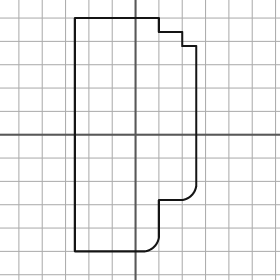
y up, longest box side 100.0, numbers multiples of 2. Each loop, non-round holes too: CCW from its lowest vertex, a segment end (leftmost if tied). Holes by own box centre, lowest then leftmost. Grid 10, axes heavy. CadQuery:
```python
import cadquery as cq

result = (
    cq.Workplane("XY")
    .moveTo(-26.0, -50.0)
    .lineTo(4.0, -50.0)
    .threePointArc((8.0, -48.0), (10.0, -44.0))
    .lineTo(10.0, -28.0)
    .lineTo(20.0, -28.0)
    .threePointArc((24.0, -26.0), (26.0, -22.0))
    .lineTo(26.0, 38.0)
    .lineTo(20.0, 38.0)
    .lineTo(20.0, 44.0)
    .lineTo(10.0, 44.0)
    .lineTo(10.0, 50.0)
    .lineTo(-26.0, 50.0)
    .close()
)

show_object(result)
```